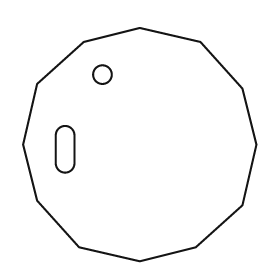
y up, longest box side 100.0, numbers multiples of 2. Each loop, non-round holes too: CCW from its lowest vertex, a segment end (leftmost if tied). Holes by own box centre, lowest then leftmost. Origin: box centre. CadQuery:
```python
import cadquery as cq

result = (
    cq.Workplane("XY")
    .moveTo(0.0, -50.0)
    .lineTo(24.0, -44.0)
    .lineTo(44.0, -26.0)
    .lineTo(50.0, 0.0)
    .lineTo(44.0, 24.0)
    .lineTo(26.0, 44.0)
    .lineTo(0.0, 50.0)
    .lineTo(-24.0, 44.0)
    .lineTo(-44.0, 26.0)
    .lineTo(-50.0, 0.0)
    .lineTo(-44.0, -24.0)
    .lineTo(-26.0, -44.0)
    .close()
    .moveTo(-36.0, -8.0)
    .threePointArc((-32.0, -12.0), (-28.0, -8.0))
    .lineTo(-28.0, 4.0)
    .threePointArc((-32.0, 8.0), (-36.0, 4.0))
    .close()
    .moveTo(-16.0, 30.0)
    .circle(4.0)
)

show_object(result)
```